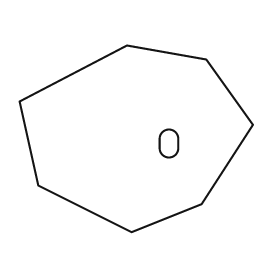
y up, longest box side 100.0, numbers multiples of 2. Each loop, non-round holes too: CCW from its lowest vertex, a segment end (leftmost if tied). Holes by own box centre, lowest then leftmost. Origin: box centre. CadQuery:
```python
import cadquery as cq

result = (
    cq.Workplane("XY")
    .moveTo(-2.0, -40.0)
    .lineTo(28.0, -28.0)
    .lineTo(50.0, 6.0)
    .lineTo(30.0, 34.0)
    .lineTo(-4.0, 40.0)
    .lineTo(-50.0, 16.0)
    .lineTo(-42.0, -20.0)
    .close()
    .moveTo(10.0, -4.0)
    .threePointArc((14.0, -8.0), (18.0, -4.0))
    .lineTo(18.0, 0.0)
    .threePointArc((14.0, 4.0), (10.0, 0.0))
    .close()
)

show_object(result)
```